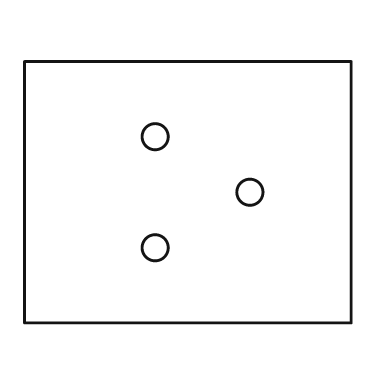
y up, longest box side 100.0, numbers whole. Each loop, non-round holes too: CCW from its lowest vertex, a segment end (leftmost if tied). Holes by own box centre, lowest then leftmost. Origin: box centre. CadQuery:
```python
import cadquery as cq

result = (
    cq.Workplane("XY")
    .moveTo(-50.0, -40.0)
    .lineTo(50.0, -40.0)
    .lineTo(50.0, 40.0)
    .lineTo(-50.0, 40.0)
    .close()
    .moveTo(-10.0, -17.0)
    .circle(4.0)
    .moveTo(19.0, 0.0)
    .circle(4.0)
    .moveTo(-10.0, 17.0)
    .circle(4.0)
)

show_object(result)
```